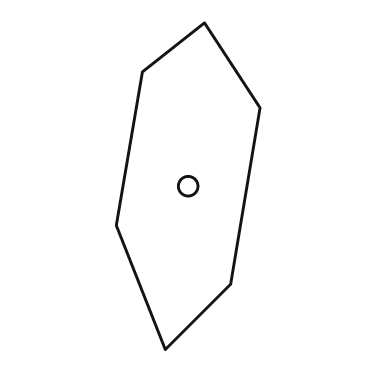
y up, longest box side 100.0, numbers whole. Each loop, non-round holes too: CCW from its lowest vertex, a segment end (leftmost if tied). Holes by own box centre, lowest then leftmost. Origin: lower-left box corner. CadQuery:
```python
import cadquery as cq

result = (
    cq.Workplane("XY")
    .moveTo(15.0, 0.0)
    .lineTo(35.0, 20.0)
    .lineTo(44.0, 74.0)
    .lineTo(27.0, 100.0)
    .lineTo(8.0, 85.0)
    .lineTo(0.0, 38.0)
    .close()
    .moveTo(22.0, 50.0)
    .circle(3.0)
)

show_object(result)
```